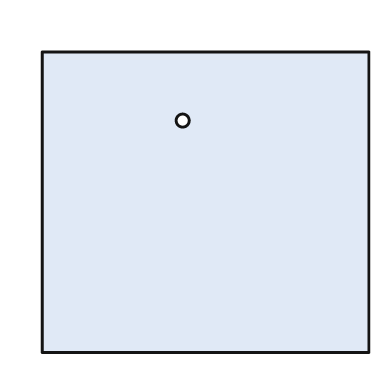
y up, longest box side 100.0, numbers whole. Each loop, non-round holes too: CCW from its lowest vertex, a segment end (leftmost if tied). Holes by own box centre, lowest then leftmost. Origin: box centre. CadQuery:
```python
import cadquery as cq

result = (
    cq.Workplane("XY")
    .moveTo(-50.0, -46.0)
    .lineTo(50.0, -46.0)
    .lineTo(50.0, 46.0)
    .lineTo(-50.0, 46.0)
    .close()
    .moveTo(-7.0, 25.0)
    .circle(2.0)
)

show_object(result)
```